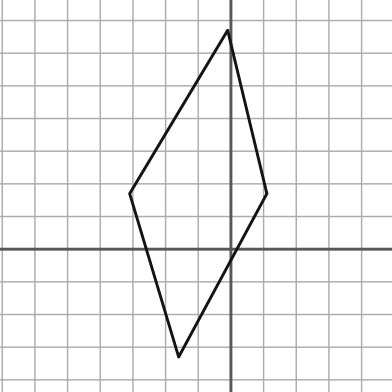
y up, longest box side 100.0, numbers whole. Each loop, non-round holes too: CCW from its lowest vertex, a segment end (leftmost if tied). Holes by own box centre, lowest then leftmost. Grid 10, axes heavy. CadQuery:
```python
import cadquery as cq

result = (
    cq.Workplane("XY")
    .moveTo(-16.0, -33.0)
    .lineTo(11.0, 17.0)
    .lineTo(-1.0, 67.0)
    .lineTo(-31.0, 17.0)
    .close()
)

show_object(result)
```